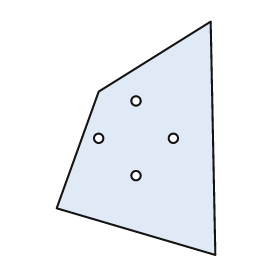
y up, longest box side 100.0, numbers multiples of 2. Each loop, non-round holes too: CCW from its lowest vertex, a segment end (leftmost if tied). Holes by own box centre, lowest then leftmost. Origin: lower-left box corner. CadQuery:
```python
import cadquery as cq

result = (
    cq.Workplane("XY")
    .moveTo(68.0, 0.0)
    .lineTo(66.0, 100.0)
    .lineTo(18.0, 70.0)
    .lineTo(0.0, 20.0)
    .close()
    .moveTo(34.0, 34.0)
    .circle(2.0)
    .moveTo(18.0, 50.0)
    .circle(2.0)
    .moveTo(50.0, 50.0)
    .circle(2.0)
    .moveTo(34.0, 66.0)
    .circle(2.0)
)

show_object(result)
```